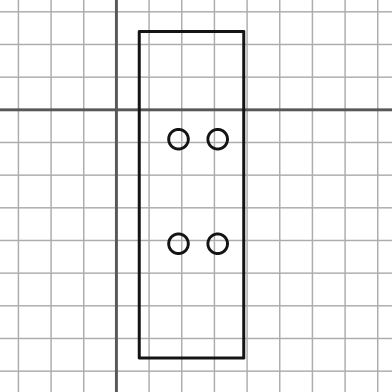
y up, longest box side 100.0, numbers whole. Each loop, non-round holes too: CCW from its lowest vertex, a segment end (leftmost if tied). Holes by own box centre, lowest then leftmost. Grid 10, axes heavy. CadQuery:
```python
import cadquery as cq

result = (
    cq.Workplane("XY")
    .moveTo(7.0, -76.0)
    .lineTo(39.0, -76.0)
    .lineTo(39.0, 24.0)
    .lineTo(7.0, 24.0)
    .close()
    .moveTo(19.0, -41.0)
    .circle(3.0)
    .moveTo(31.0, -41.0)
    .circle(3.0)
    .moveTo(19.0, -9.0)
    .circle(3.0)
    .moveTo(31.0, -9.0)
    .circle(3.0)
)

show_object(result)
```